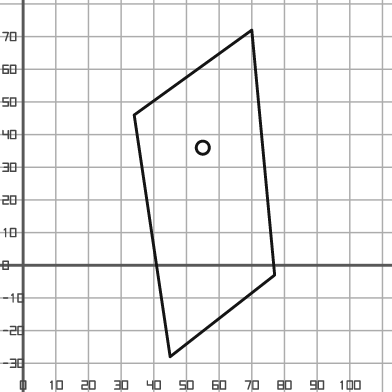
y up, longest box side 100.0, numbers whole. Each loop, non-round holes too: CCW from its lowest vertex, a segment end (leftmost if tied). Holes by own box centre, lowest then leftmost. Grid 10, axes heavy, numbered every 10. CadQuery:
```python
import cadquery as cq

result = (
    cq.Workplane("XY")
    .moveTo(45.0, -28.0)
    .lineTo(77.0, -3.0)
    .lineTo(70.0, 72.0)
    .lineTo(34.0, 46.0)
    .close()
    .moveTo(55.0, 36.0)
    .circle(2.0)
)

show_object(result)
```